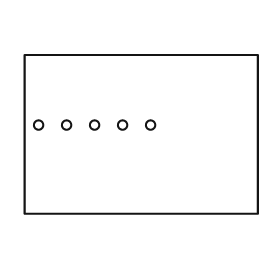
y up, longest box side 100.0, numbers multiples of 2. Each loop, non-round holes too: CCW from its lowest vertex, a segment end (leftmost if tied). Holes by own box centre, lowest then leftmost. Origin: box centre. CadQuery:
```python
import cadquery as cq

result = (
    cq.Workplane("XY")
    .moveTo(-50.0, -34.0)
    .lineTo(50.0, -34.0)
    .lineTo(50.0, 34.0)
    .lineTo(-50.0, 34.0)
    .close()
    .moveTo(-44.0, 4.0)
    .circle(2.0)
    .moveTo(-32.0, 4.0)
    .circle(2.0)
    .moveTo(-20.0, 4.0)
    .circle(2.0)
    .moveTo(-8.0, 4.0)
    .circle(2.0)
    .moveTo(4.0, 4.0)
    .circle(2.0)
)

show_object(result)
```